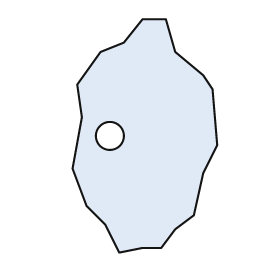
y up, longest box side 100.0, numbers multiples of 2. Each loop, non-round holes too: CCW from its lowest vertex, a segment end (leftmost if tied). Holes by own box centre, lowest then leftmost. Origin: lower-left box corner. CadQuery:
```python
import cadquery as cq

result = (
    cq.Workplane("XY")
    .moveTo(20.0, 0.0)
    .lineTo(30.0, 2.0)
    .lineTo(38.0, 2.0)
    .lineTo(44.0, 10.0)
    .lineTo(52.0, 16.0)
    .lineTo(56.0, 34.0)
    .lineTo(62.0, 46.0)
    .lineTo(60.0, 70.0)
    .lineTo(56.0, 76.0)
    .lineTo(44.0, 86.0)
    .lineTo(40.0, 100.0)
    .lineTo(30.0, 100.0)
    .lineTo(22.0, 90.0)
    .lineTo(12.0, 86.0)
    .lineTo(2.0, 72.0)
    .lineTo(4.0, 58.0)
    .lineTo(0.0, 36.0)
    .lineTo(6.0, 20.0)
    .lineTo(14.0, 12.0)
    .close()
    .moveTo(16.0, 50.0)
    .circle(6.0)
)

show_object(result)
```